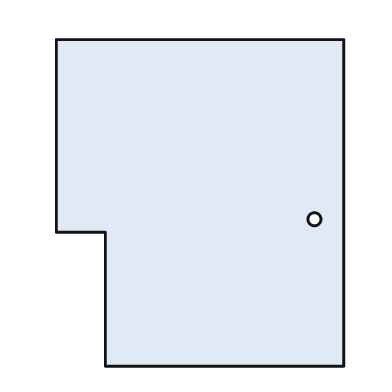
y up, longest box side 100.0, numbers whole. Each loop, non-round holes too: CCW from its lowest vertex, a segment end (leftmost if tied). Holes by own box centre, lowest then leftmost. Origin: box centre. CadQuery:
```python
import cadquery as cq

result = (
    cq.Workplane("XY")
    .moveTo(-29.0, -50.0)
    .lineTo(44.0, -50.0)
    .lineTo(44.0, 50.0)
    .lineTo(-44.0, 50.0)
    .lineTo(-44.0, -9.0)
    .lineTo(-29.0, -9.0)
    .close()
    .moveTo(35.0, -5.0)
    .circle(2.0)
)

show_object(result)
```